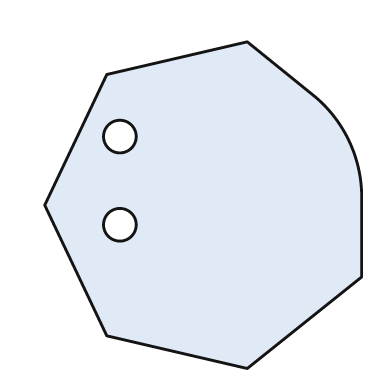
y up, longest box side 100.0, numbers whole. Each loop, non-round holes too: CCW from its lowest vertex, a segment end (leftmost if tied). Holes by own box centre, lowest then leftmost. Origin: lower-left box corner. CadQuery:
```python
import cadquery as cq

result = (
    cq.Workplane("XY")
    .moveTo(62.0, 0.0)
    .lineTo(97.0, 28.0)
    .lineTo(97.0, 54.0)
    .threePointArc((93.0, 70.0), (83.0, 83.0))
    .lineTo(62.0, 100.0)
    .lineTo(19.0, 90.0)
    .lineTo(0.0, 50.0)
    .lineTo(19.0, 10.0)
    .close()
    .moveTo(23.0, 44.0)
    .circle(5.0)
    .moveTo(23.0, 71.0)
    .circle(5.0)
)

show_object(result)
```